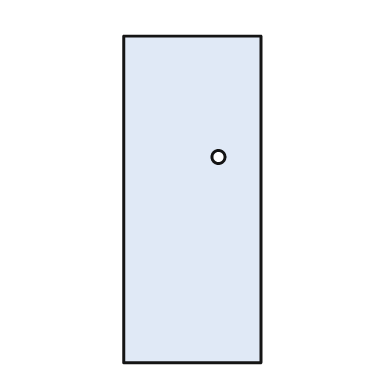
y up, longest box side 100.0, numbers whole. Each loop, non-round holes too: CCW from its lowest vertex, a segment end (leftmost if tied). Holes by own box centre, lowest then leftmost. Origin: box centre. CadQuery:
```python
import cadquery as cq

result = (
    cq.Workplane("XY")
    .moveTo(-21.0, -50.0)
    .lineTo(21.0, -50.0)
    .lineTo(21.0, 50.0)
    .lineTo(-21.0, 50.0)
    .close()
    .moveTo(8.0, 13.0)
    .circle(2.0)
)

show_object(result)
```